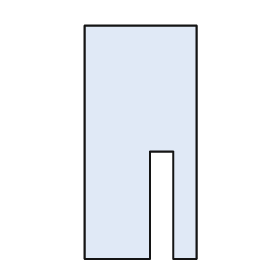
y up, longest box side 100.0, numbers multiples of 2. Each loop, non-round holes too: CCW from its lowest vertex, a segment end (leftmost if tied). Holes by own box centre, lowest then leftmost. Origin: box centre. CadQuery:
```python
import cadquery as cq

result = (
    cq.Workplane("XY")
    .moveTo(-24.0, -50.0)
    .lineTo(4.0, -50.0)
    .lineTo(4.0, -4.0)
    .lineTo(14.0, -4.0)
    .lineTo(14.0, -50.0)
    .lineTo(24.0, -50.0)
    .lineTo(24.0, 50.0)
    .lineTo(-24.0, 50.0)
    .close()
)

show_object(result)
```